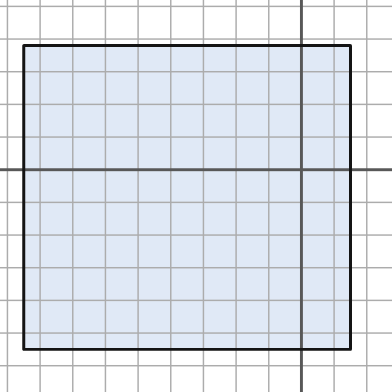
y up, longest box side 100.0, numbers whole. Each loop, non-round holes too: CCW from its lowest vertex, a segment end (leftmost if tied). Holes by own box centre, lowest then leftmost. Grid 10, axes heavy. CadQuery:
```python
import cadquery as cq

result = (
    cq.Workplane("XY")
    .moveTo(-85.0, -55.0)
    .lineTo(15.0, -55.0)
    .lineTo(15.0, 38.0)
    .lineTo(-85.0, 38.0)
    .close()
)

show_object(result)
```